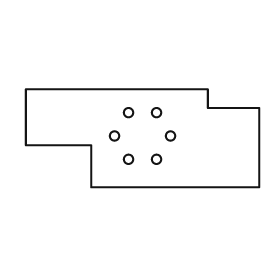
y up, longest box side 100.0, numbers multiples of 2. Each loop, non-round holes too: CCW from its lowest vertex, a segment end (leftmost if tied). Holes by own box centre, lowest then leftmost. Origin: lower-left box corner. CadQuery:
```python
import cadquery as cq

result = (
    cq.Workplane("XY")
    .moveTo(28.0, 0.0)
    .lineTo(100.0, 0.0)
    .lineTo(100.0, 34.0)
    .lineTo(78.0, 34.0)
    .lineTo(78.0, 42.0)
    .lineTo(0.0, 42.0)
    .lineTo(0.0, 18.0)
    .lineTo(28.0, 18.0)
    .close()
    .moveTo(44.0, 12.0)
    .circle(2.0)
    .moveTo(56.0, 12.0)
    .circle(2.0)
    .moveTo(38.0, 22.0)
    .circle(2.0)
    .moveTo(62.0, 22.0)
    .circle(2.0)
    .moveTo(44.0, 32.0)
    .circle(2.0)
    .moveTo(56.0, 32.0)
    .circle(2.0)
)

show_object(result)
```